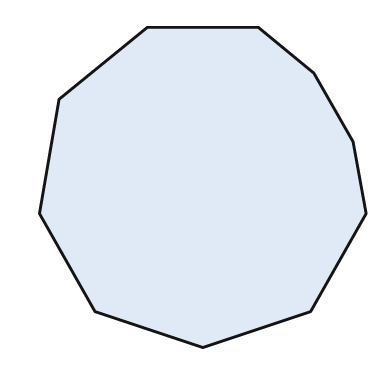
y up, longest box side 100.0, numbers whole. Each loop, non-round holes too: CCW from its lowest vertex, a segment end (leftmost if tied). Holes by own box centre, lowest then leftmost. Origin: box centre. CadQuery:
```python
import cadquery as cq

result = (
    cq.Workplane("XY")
    .moveTo(0.0, -49.0)
    .lineTo(33.0, -38.0)
    .lineTo(50.0, -8.0)
    .lineTo(46.0, 14.0)
    .lineTo(34.0, 35.0)
    .lineTo(17.0, 49.0)
    .lineTo(-17.0, 49.0)
    .lineTo(-44.0, 27.0)
    .lineTo(-50.0, -8.0)
    .lineTo(-33.0, -38.0)
    .close()
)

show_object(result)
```